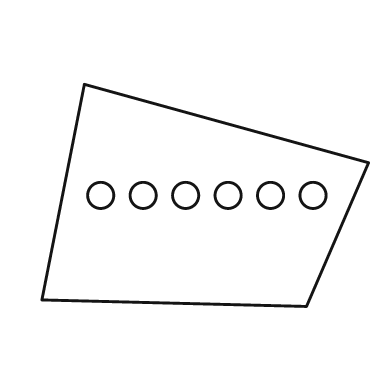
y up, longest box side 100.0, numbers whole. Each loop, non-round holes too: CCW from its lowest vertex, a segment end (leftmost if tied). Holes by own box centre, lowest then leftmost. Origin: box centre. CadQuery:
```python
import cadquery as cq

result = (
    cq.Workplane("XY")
    .moveTo(31.0, -34.0)
    .lineTo(50.0, 10.0)
    .lineTo(-37.0, 34.0)
    .lineTo(-50.0, -32.0)
    .close()
    .moveTo(-32.0, 0.0)
    .circle(4.0)
    .moveTo(-19.0, 0.0)
    .circle(4.0)
    .moveTo(-6.0, 0.0)
    .circle(4.0)
    .moveTo(7.0, 0.0)
    .circle(4.0)
    .moveTo(20.0, 0.0)
    .circle(4.0)
    .moveTo(33.0, 0.0)
    .circle(4.0)
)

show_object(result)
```